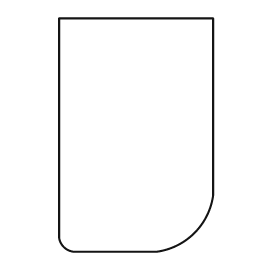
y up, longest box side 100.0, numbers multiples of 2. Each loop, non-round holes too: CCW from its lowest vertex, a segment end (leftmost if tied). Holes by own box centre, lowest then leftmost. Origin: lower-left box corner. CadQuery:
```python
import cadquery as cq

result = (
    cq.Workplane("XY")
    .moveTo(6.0, 0.0)
    .lineTo(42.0, 0.0)
    .threePointArc((58.0, 8.0), (66.0, 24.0))
    .lineTo(66.0, 100.0)
    .lineTo(0.0, 100.0)
    .lineTo(0.0, 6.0)
    .threePointArc((2.0, 2.0), (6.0, 0.0))
    .close()
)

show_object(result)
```